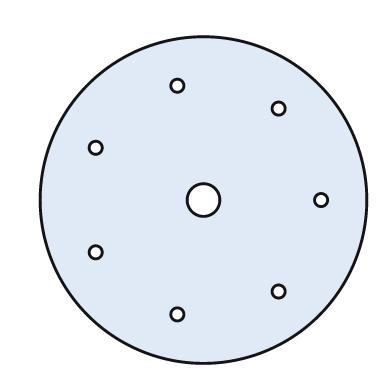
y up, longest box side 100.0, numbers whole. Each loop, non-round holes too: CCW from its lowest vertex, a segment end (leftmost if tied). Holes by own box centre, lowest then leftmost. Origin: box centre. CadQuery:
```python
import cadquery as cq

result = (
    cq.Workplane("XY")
    .moveTo(0.0, 0.0)
    .circle(50.0)
    .moveTo(-8.0, -35.0)
    .circle(2.0)
    .moveTo(23.0, -28.0)
    .circle(2.0)
    .moveTo(-33.0, -16.0)
    .circle(2.0)
    .moveTo(0.0, 0.0)
    .circle(5.0)
    .moveTo(36.0, 0.0)
    .circle(2.0)
    .moveTo(-33.0, 16.0)
    .circle(2.0)
    .moveTo(23.0, 28.0)
    .circle(2.0)
    .moveTo(-8.0, 35.0)
    .circle(2.0)
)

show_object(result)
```